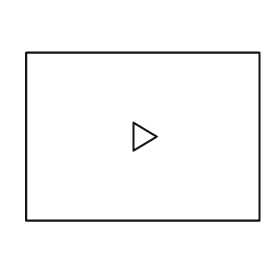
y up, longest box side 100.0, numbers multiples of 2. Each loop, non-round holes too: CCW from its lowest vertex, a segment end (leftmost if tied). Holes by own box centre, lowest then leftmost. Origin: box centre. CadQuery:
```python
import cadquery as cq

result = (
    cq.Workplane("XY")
    .moveTo(-50.0, -36.0)
    .lineTo(50.0, -36.0)
    .lineTo(50.0, 36.0)
    .lineTo(-50.0, 36.0)
    .close()
    .moveTo(-4.0, -6.0)
    .lineTo(6.0, 0.0)
    .lineTo(-4.0, 6.0)
    .close()
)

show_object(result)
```